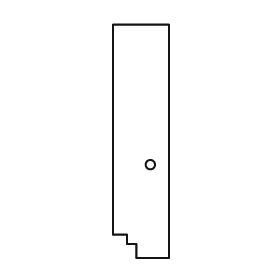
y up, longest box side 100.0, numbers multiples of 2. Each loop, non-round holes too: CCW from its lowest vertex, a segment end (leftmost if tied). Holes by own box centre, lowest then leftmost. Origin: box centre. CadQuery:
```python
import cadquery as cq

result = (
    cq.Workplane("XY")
    .moveTo(-2.0, -50.0)
    .lineTo(12.0, -50.0)
    .lineTo(12.0, 50.0)
    .lineTo(-12.0, 50.0)
    .lineTo(-12.0, -40.0)
    .lineTo(-6.0, -40.0)
    .lineTo(-6.0, -44.0)
    .lineTo(-2.0, -44.0)
    .close()
    .moveTo(4.0, -10.0)
    .circle(2.0)
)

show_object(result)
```